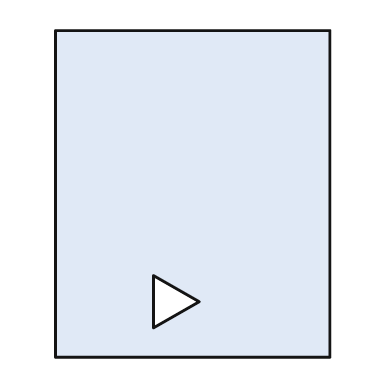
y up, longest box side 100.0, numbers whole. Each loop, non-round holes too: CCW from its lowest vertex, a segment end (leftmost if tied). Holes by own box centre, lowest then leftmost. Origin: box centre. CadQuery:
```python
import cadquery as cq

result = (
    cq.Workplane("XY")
    .moveTo(-42.0, -50.0)
    .lineTo(42.0, -50.0)
    .lineTo(42.0, 50.0)
    .lineTo(-42.0, 50.0)
    .close()
    .moveTo(-12.0, -41.0)
    .lineTo(2.0, -33.0)
    .lineTo(-12.0, -25.0)
    .close()
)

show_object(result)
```